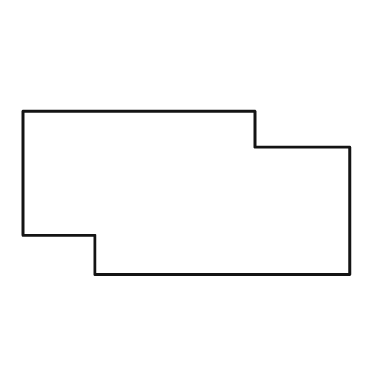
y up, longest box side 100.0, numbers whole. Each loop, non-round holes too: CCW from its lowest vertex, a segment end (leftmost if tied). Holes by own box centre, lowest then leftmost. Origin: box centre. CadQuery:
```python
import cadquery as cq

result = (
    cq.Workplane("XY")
    .moveTo(-28.0, -25.0)
    .lineTo(50.0, -25.0)
    .lineTo(50.0, 14.0)
    .lineTo(21.0, 14.0)
    .lineTo(21.0, 25.0)
    .lineTo(-50.0, 25.0)
    .lineTo(-50.0, -13.0)
    .lineTo(-28.0, -13.0)
    .close()
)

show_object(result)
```